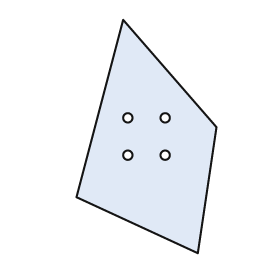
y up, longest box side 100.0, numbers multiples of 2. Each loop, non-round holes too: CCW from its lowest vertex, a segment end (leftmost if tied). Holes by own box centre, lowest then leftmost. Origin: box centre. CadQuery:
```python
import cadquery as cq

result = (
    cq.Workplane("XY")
    .moveTo(22.0, -50.0)
    .lineTo(30.0, 4.0)
    .lineTo(-10.0, 50.0)
    .lineTo(-30.0, -26.0)
    .close()
    .moveTo(-8.0, -8.0)
    .circle(2.0)
    .moveTo(8.0, -8.0)
    .circle(2.0)
    .moveTo(-8.0, 8.0)
    .circle(2.0)
    .moveTo(8.0, 8.0)
    .circle(2.0)
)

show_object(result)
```